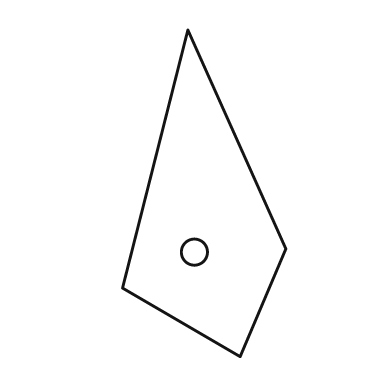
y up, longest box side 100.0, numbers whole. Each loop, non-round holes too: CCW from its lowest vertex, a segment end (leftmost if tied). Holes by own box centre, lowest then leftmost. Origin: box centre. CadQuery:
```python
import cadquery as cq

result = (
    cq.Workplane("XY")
    .moveTo(11.0, -50.0)
    .lineTo(25.0, -17.0)
    .lineTo(-5.0, 50.0)
    .lineTo(-25.0, -29.0)
    .close()
    .moveTo(-3.0, -18.0)
    .circle(4.0)
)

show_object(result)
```